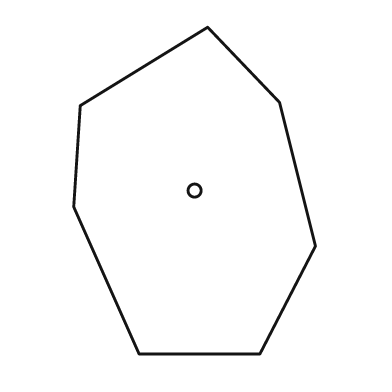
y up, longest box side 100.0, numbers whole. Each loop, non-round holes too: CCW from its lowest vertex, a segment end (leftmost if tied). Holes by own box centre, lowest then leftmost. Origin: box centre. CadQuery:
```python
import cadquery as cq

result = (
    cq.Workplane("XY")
    .moveTo(-17.0, -50.0)
    .lineTo(20.0, -50.0)
    .lineTo(37.0, -17.0)
    .lineTo(26.0, 27.0)
    .lineTo(4.0, 50.0)
    .lineTo(-35.0, 26.0)
    .lineTo(-37.0, -5.0)
    .close()
    .moveTo(0.0, 0.0)
    .circle(2.0)
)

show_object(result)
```